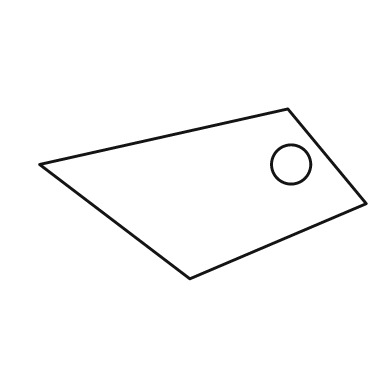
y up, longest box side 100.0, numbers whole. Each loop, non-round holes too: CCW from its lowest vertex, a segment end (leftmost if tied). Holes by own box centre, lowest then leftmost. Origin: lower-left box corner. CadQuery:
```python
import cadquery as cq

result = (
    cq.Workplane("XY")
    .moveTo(46.0, 0.0)
    .lineTo(100.0, 23.0)
    .lineTo(76.0, 52.0)
    .lineTo(0.0, 35.0)
    .close()
    .moveTo(77.0, 35.0)
    .circle(6.0)
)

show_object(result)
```